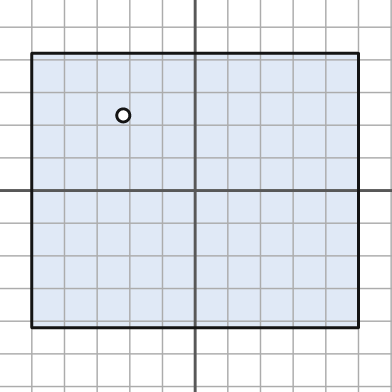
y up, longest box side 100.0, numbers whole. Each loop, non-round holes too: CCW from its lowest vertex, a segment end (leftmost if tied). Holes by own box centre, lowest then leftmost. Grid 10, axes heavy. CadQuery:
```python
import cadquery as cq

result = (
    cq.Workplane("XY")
    .moveTo(-50.0, -42.0)
    .lineTo(50.0, -42.0)
    .lineTo(50.0, 42.0)
    .lineTo(-50.0, 42.0)
    .close()
    .moveTo(-22.0, 23.0)
    .circle(2.0)
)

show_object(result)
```